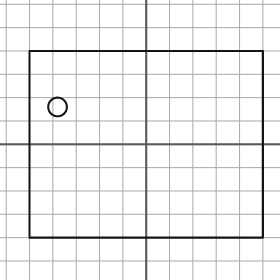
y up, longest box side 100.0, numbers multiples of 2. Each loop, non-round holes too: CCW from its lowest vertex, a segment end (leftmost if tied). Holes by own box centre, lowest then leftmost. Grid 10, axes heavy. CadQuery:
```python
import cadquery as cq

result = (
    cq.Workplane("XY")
    .moveTo(-50.0, -40.0)
    .lineTo(50.0, -40.0)
    .lineTo(50.0, 40.0)
    .lineTo(-50.0, 40.0)
    .close()
    .moveTo(-38.0, 16.0)
    .circle(4.0)
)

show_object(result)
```